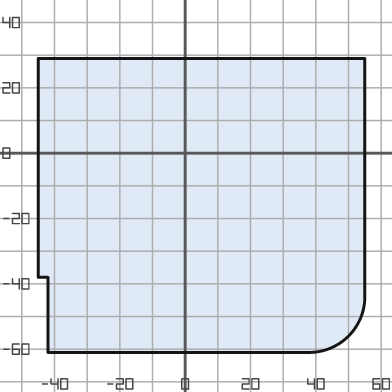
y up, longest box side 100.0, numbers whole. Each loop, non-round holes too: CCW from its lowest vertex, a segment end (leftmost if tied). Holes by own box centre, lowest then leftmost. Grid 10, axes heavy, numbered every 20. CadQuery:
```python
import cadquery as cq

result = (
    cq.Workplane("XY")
    .moveTo(-42.0, -61.0)
    .lineTo(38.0, -61.0)
    .threePointArc((50.0, -56.0), (55.0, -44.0))
    .lineTo(55.0, 29.0)
    .lineTo(-45.0, 29.0)
    .lineTo(-45.0, -38.0)
    .lineTo(-42.0, -38.0)
    .close()
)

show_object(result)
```